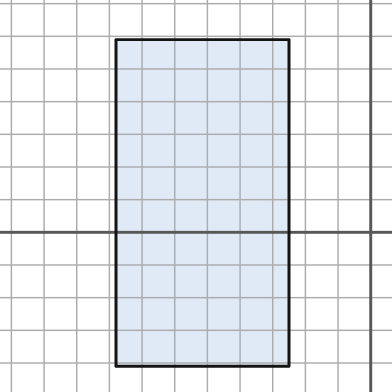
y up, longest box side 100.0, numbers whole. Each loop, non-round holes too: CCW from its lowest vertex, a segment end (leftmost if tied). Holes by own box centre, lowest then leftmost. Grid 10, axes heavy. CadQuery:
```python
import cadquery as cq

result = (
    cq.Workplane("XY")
    .moveTo(-78.0, -41.0)
    .lineTo(-25.0, -41.0)
    .lineTo(-25.0, 59.0)
    .lineTo(-78.0, 59.0)
    .close()
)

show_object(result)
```